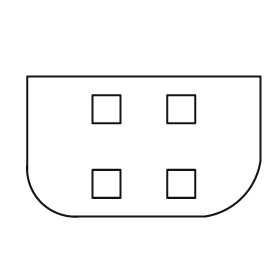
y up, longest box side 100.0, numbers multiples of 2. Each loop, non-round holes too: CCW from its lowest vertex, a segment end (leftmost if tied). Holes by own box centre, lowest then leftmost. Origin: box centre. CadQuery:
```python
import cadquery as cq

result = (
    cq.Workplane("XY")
    .moveTo(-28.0, -30.0)
    .lineTo(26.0, -30.0)
    .threePointArc((42.0, -22.0), (50.0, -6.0))
    .lineTo(50.0, 30.0)
    .lineTo(-50.0, 30.0)
    .lineTo(-50.0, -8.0)
    .threePointArc((-44.0, -24.0), (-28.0, -30.0))
    .close()
    .moveTo(-22.0, -22.0)
    .lineTo(-10.0, -22.0)
    .lineTo(-10.0, -10.0)
    .lineTo(-22.0, -10.0)
    .close()
    .moveTo(10.0, -22.0)
    .lineTo(22.0, -22.0)
    .lineTo(22.0, -10.0)
    .lineTo(10.0, -10.0)
    .close()
    .moveTo(-22.0, 10.0)
    .lineTo(-10.0, 10.0)
    .lineTo(-10.0, 22.0)
    .lineTo(-22.0, 22.0)
    .close()
    .moveTo(10.0, 10.0)
    .lineTo(22.0, 10.0)
    .lineTo(22.0, 22.0)
    .lineTo(10.0, 22.0)
    .close()
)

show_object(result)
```